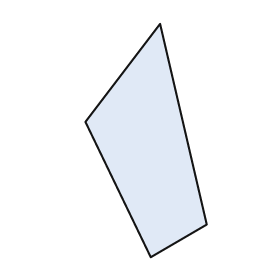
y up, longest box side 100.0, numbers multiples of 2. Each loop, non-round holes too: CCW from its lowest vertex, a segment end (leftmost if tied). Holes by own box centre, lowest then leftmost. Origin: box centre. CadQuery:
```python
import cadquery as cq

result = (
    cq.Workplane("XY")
    .moveTo(2.0, -50.0)
    .lineTo(26.0, -36.0)
    .lineTo(6.0, 50.0)
    .lineTo(-26.0, 8.0)
    .close()
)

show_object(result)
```